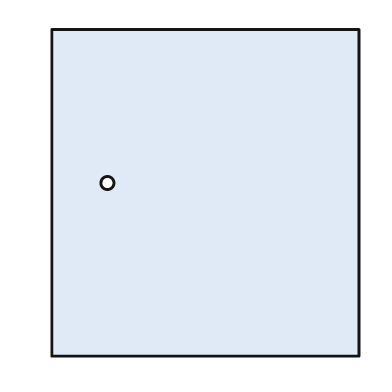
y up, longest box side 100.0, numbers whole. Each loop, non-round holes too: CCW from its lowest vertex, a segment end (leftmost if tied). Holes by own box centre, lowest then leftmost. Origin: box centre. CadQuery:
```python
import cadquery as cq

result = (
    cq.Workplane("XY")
    .moveTo(-47.0, -50.0)
    .lineTo(47.0, -50.0)
    .lineTo(47.0, 50.0)
    .lineTo(-47.0, 50.0)
    .close()
    .moveTo(-30.0, 3.0)
    .circle(2.0)
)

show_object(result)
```